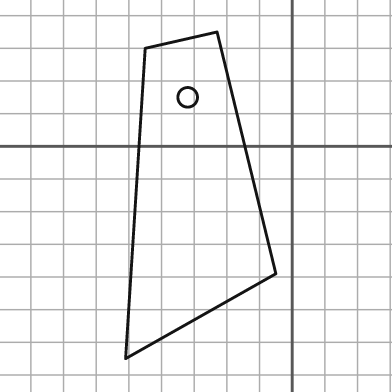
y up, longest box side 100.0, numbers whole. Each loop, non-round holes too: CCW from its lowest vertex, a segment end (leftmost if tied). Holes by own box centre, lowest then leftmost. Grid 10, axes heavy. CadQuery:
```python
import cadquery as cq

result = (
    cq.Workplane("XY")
    .moveTo(-51.0, -65.0)
    .lineTo(-5.0, -39.0)
    .lineTo(-23.0, 35.0)
    .lineTo(-45.0, 30.0)
    .close()
    .moveTo(-32.0, 15.0)
    .circle(3.0)
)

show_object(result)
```